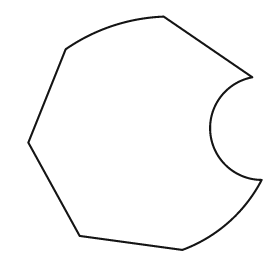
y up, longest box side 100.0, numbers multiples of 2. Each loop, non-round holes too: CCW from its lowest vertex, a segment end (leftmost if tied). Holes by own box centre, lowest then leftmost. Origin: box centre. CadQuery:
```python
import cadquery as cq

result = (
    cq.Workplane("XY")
    .moveTo(16.0, -50.0)
    .threePointArc((36.0, -38.0), (50.0, -20.0))
    .threePointArc((28.0, 0.0), (46.0, 24.0))
    .lineTo(8.0, 50.0)
    .threePointArc((-14.0, 46.0), (-34.0, 36.0))
    .lineTo(-50.0, -4.0)
    .lineTo(-28.0, -44.0)
    .close()
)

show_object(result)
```